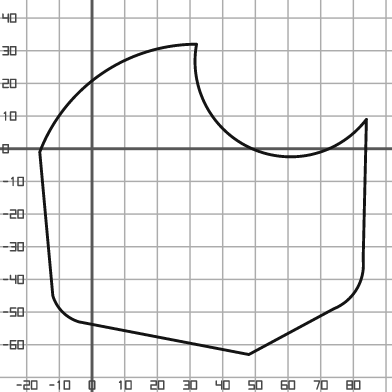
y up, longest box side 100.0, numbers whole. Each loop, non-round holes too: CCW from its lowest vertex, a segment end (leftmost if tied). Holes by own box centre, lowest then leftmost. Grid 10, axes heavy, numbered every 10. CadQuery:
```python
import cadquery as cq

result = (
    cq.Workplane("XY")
    .moveTo(48.0, -63.0)
    .lineTo(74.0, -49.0)
    .threePointArc((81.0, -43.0), (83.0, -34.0))
    .lineTo(84.0, 9.0)
    .threePointArc((49.0, 0.0), (32.0, 32.0))
    .threePointArc((3.0, 23.0), (-16.0, -1.0))
    .lineTo(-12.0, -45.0)
    .threePointArc((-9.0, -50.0), (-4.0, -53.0))
    .close()
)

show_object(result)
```